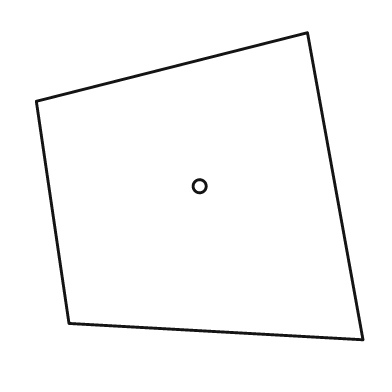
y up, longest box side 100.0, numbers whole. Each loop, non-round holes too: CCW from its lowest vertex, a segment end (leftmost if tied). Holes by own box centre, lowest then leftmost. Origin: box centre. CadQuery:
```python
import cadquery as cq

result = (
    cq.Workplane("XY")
    .moveTo(50.0, -47.0)
    .lineTo(33.0, 47.0)
    .lineTo(-50.0, 26.0)
    .lineTo(-40.0, -42.0)
    .close()
    .moveTo(0.0, 0.0)
    .circle(2.0)
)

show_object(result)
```